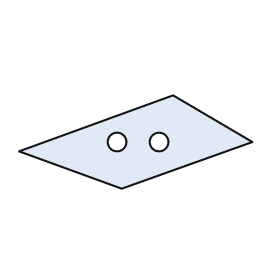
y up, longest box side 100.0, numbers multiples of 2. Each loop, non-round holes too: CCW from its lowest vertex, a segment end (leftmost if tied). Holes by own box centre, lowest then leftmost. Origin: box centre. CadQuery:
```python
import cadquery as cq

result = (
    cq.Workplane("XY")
    .moveTo(-6.0, -20.0)
    .lineTo(50.0, 0.0)
    .lineTo(16.0, 20.0)
    .lineTo(-50.0, -4.0)
    .close()
    .moveTo(-8.0, 0.0)
    .circle(4.0)
    .moveTo(10.0, 0.0)
    .circle(4.0)
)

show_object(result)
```